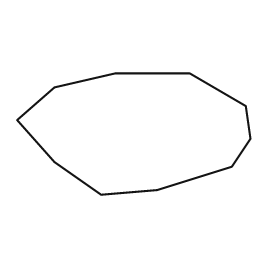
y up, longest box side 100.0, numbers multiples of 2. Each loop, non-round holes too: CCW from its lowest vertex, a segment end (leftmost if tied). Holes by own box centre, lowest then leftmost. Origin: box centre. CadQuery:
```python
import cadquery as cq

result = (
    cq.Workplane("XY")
    .moveTo(-14.0, -26.0)
    .lineTo(10.0, -24.0)
    .lineTo(42.0, -14.0)
    .lineTo(50.0, -2.0)
    .lineTo(48.0, 12.0)
    .lineTo(24.0, 26.0)
    .lineTo(-8.0, 26.0)
    .lineTo(-34.0, 20.0)
    .lineTo(-50.0, 6.0)
    .lineTo(-34.0, -12.0)
    .close()
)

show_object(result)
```